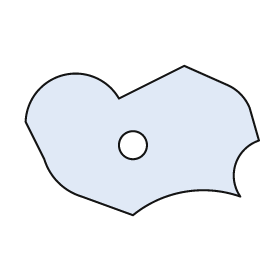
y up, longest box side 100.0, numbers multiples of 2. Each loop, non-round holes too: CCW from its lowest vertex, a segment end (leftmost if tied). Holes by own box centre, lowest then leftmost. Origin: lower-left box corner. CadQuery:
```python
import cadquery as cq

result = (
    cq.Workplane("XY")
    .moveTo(46.0, 0.0)
    .threePointArc((68.0, 10.0), (92.0, 8.0))
    .threePointArc((90.0, 22.0), (100.0, 32.0))
    .lineTo(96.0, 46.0)
    .threePointArc((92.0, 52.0), (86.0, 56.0))
    .lineTo(68.0, 64.0)
    .lineTo(40.0, 50.0)
    .threePointArc((16.0, 60.0), (0.0, 40.0))
    .lineTo(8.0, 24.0)
    .threePointArc((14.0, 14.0), (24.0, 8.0))
    .close()
    .moveTo(46.0, 30.0)
    .circle(6.0)
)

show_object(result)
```